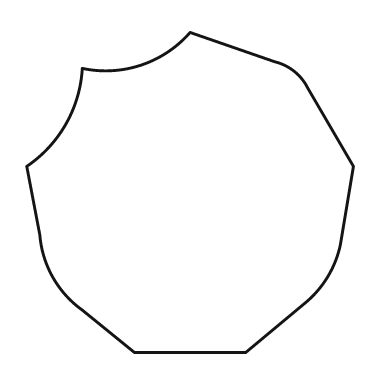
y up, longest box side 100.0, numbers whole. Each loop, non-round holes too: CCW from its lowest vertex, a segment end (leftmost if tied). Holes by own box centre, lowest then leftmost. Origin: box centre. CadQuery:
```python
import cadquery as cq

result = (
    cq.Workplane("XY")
    .moveTo(-17.0, -49.0)
    .lineTo(17.0, -49.0)
    .lineTo(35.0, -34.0)
    .threePointArc((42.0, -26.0), (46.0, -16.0))
    .lineTo(50.0, 8.0)
    .lineTo(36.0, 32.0)
    .threePointArc((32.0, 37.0), (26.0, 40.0))
    .lineTo(0.0, 49.0)
    .threePointArc((-15.0, 39.0), (-33.0, 38.0))
    .threePointArc((-38.0, 21.0), (-50.0, 8.0))
    .lineTo(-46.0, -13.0)
    .threePointArc((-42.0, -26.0), (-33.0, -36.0))
    .close()
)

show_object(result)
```